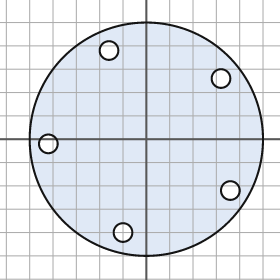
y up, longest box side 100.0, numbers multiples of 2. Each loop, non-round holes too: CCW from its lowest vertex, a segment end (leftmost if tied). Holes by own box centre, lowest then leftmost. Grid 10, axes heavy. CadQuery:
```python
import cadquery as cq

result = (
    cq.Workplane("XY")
    .moveTo(0.0, 0.0)
    .circle(50.0)
    .moveTo(-10.0, -40.0)
    .circle(4.0)
    .moveTo(36.0, -22.0)
    .circle(4.0)
    .moveTo(-42.0, -2.0)
    .circle(4.0)
    .moveTo(32.0, 26.0)
    .circle(4.0)
    .moveTo(-16.0, 38.0)
    .circle(4.0)
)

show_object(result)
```